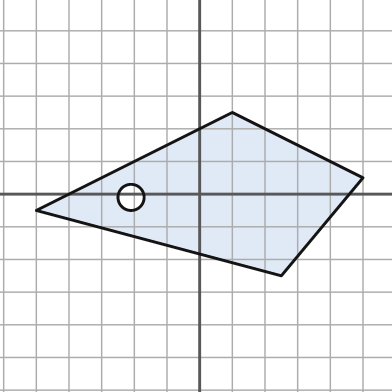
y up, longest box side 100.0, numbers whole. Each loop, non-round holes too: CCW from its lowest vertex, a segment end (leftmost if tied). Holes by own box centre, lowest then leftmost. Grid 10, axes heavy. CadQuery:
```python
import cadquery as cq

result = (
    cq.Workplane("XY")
    .moveTo(25.0, -25.0)
    .lineTo(50.0, 5.0)
    .lineTo(10.0, 25.0)
    .lineTo(-50.0, -5.0)
    .close()
    .moveTo(-21.0, -1.0)
    .circle(4.0)
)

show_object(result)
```